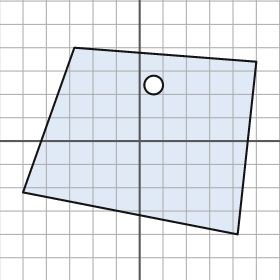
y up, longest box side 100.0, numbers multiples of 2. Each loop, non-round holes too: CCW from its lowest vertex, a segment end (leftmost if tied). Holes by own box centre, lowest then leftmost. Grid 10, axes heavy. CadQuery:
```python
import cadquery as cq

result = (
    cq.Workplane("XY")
    .moveTo(42.0, -40.0)
    .lineTo(50.0, 34.0)
    .lineTo(-28.0, 40.0)
    .lineTo(-50.0, -22.0)
    .close()
    .moveTo(6.0, 24.0)
    .circle(4.0)
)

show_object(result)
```